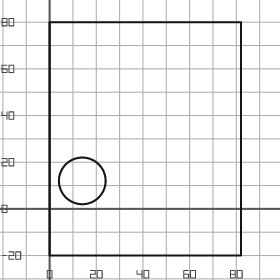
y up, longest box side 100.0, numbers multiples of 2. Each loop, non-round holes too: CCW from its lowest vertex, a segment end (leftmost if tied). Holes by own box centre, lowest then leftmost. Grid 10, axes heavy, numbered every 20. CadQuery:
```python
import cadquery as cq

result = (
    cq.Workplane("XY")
    .moveTo(0.0, -20.0)
    .lineTo(82.0, -20.0)
    .lineTo(82.0, 80.0)
    .lineTo(0.0, 80.0)
    .close()
    .moveTo(14.0, 12.0)
    .circle(10.0)
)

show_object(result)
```